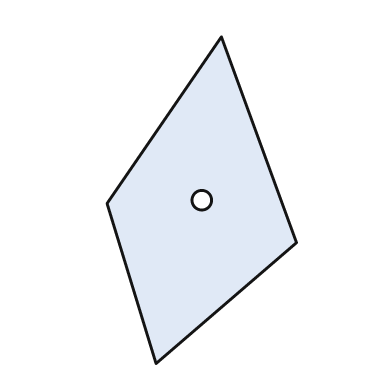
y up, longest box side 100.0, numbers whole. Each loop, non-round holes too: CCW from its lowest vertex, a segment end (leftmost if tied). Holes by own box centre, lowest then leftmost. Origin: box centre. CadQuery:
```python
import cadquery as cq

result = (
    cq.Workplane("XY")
    .moveTo(-14.0, -50.0)
    .lineTo(29.0, -13.0)
    .lineTo(6.0, 50.0)
    .lineTo(-29.0, -1.0)
    .close()
    .moveTo(0.0, 0.0)
    .circle(3.0)
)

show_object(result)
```